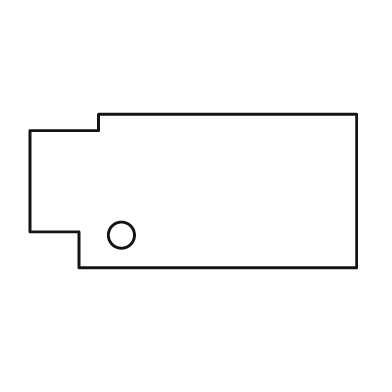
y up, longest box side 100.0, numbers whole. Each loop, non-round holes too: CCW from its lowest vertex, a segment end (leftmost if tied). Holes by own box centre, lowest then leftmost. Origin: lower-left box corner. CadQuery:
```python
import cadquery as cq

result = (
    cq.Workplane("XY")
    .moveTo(15.0, 0.0)
    .lineTo(100.0, 0.0)
    .lineTo(100.0, 47.0)
    .lineTo(21.0, 47.0)
    .lineTo(21.0, 42.0)
    .lineTo(0.0, 42.0)
    .lineTo(0.0, 11.0)
    .lineTo(15.0, 11.0)
    .close()
    .moveTo(28.0, 10.0)
    .circle(4.0)
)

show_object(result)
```